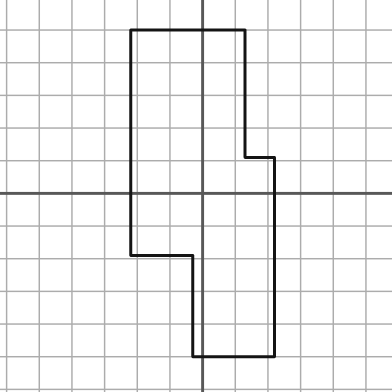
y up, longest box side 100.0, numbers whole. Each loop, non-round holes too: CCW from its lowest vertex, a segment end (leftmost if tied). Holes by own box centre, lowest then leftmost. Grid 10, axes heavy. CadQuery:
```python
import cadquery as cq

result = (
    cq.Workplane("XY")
    .moveTo(-3.0, -50.0)
    .lineTo(22.0, -50.0)
    .lineTo(22.0, 11.0)
    .lineTo(13.0, 11.0)
    .lineTo(13.0, 50.0)
    .lineTo(-22.0, 50.0)
    .lineTo(-22.0, -19.0)
    .lineTo(-3.0, -19.0)
    .close()
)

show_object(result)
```